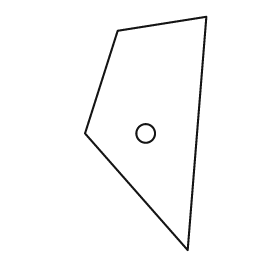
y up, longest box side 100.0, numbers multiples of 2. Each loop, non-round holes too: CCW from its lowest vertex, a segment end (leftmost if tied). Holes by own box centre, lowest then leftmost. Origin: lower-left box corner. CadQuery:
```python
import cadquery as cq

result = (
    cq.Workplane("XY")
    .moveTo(44.0, 0.0)
    .lineTo(52.0, 100.0)
    .lineTo(14.0, 94.0)
    .lineTo(0.0, 50.0)
    .close()
    .moveTo(26.0, 50.0)
    .circle(4.0)
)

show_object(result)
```